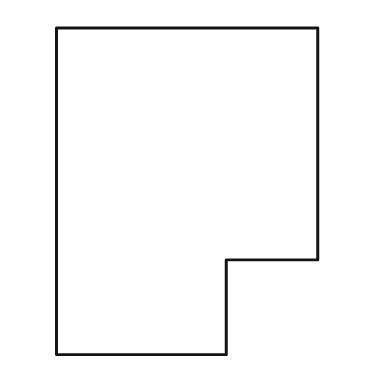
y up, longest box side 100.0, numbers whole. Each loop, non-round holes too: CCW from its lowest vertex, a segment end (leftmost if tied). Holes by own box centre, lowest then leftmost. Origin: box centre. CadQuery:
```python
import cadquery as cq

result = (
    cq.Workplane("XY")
    .moveTo(-40.0, -50.0)
    .lineTo(12.0, -50.0)
    .lineTo(12.0, -21.0)
    .lineTo(40.0, -21.0)
    .lineTo(40.0, 50.0)
    .lineTo(-40.0, 50.0)
    .close()
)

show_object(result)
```